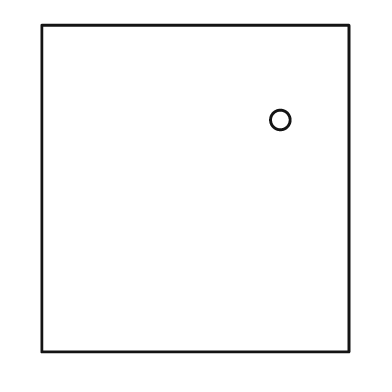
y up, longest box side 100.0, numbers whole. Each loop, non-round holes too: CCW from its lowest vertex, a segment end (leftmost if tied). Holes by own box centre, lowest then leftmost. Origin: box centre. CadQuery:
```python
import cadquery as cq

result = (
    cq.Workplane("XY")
    .moveTo(-47.0, -50.0)
    .lineTo(47.0, -50.0)
    .lineTo(47.0, 50.0)
    .lineTo(-47.0, 50.0)
    .close()
    .moveTo(26.0, 21.0)
    .circle(3.0)
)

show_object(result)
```